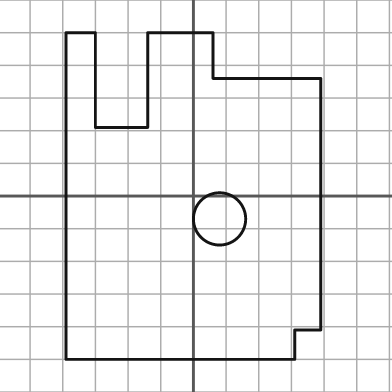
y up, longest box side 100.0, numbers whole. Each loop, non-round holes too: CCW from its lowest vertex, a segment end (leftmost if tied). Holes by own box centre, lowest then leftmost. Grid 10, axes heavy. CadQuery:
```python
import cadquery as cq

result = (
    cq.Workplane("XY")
    .moveTo(-39.0, -50.0)
    .lineTo(31.0, -50.0)
    .lineTo(31.0, -41.0)
    .lineTo(39.0, -41.0)
    .lineTo(39.0, 36.0)
    .lineTo(6.0, 36.0)
    .lineTo(6.0, 50.0)
    .lineTo(-14.0, 50.0)
    .lineTo(-14.0, 21.0)
    .lineTo(-30.0, 21.0)
    .lineTo(-30.0, 50.0)
    .lineTo(-39.0, 50.0)
    .close()
    .moveTo(8.0, -7.0)
    .circle(8.0)
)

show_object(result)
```